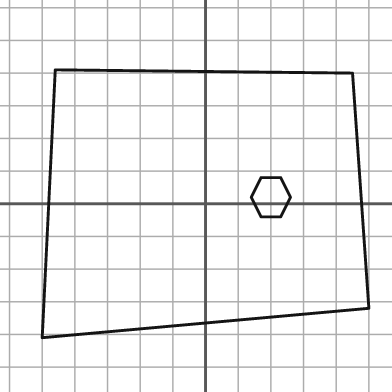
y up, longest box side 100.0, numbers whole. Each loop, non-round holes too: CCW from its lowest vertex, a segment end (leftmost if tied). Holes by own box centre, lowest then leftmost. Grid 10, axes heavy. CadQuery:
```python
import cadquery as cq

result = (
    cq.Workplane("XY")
    .moveTo(-50.0, -41.0)
    .lineTo(50.0, -32.0)
    .lineTo(45.0, 40.0)
    .lineTo(-46.0, 41.0)
    .close()
    .moveTo(17.0, -4.0)
    .lineTo(23.0, -4.0)
    .lineTo(26.0, 2.0)
    .lineTo(23.0, 8.0)
    .lineTo(17.0, 8.0)
    .lineTo(14.0, 2.0)
    .close()
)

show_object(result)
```